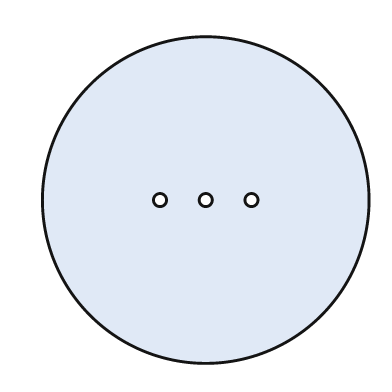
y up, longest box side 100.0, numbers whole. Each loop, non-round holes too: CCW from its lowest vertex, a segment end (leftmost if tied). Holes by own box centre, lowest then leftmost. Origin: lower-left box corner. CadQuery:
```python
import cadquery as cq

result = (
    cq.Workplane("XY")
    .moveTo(50.0, 50.0)
    .circle(50.0)
    .moveTo(36.0, 50.0)
    .circle(2.0)
    .moveTo(50.0, 50.0)
    .circle(2.0)
    .moveTo(64.0, 50.0)
    .circle(2.0)
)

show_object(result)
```